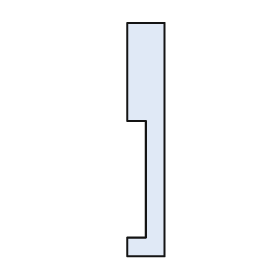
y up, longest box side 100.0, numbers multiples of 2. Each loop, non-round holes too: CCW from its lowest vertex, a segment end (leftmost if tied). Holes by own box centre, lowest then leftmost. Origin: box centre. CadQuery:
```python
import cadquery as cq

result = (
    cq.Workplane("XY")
    .moveTo(-8.0, -50.0)
    .lineTo(8.0, -50.0)
    .lineTo(8.0, 50.0)
    .lineTo(-8.0, 50.0)
    .lineTo(-8.0, 8.0)
    .lineTo(0.0, 8.0)
    .lineTo(0.0, -42.0)
    .lineTo(-8.0, -42.0)
    .close()
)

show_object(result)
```